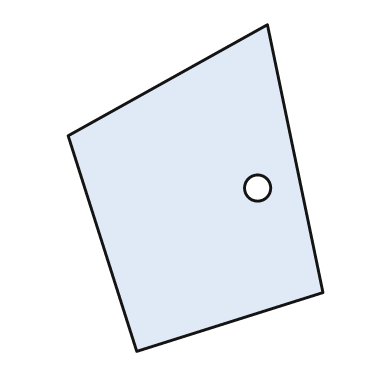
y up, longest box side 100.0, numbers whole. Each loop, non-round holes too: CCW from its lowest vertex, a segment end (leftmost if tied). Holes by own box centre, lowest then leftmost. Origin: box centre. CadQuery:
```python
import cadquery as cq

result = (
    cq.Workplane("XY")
    .moveTo(-18.0, -50.0)
    .lineTo(39.0, -32.0)
    .lineTo(22.0, 50.0)
    .lineTo(-39.0, 16.0)
    .close()
    .moveTo(19.0, 0.0)
    .circle(4.0)
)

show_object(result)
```